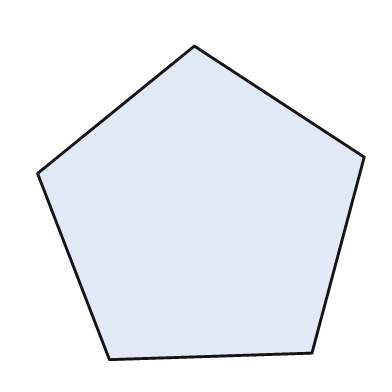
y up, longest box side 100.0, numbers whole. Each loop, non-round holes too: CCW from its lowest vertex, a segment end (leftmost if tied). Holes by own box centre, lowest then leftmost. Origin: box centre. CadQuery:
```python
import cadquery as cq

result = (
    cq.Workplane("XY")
    .moveTo(-28.0, -48.0)
    .lineTo(34.0, -46.0)
    .lineTo(50.0, 14.0)
    .lineTo(-2.0, 48.0)
    .lineTo(-50.0, 9.0)
    .close()
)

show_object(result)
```